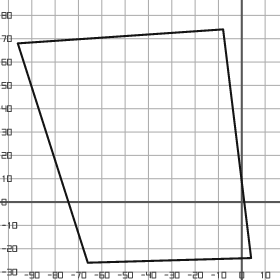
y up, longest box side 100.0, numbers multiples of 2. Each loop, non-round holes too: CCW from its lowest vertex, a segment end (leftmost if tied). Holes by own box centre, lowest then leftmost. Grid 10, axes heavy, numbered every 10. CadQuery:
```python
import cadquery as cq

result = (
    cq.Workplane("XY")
    .moveTo(-66.0, -26.0)
    .lineTo(4.0, -24.0)
    .lineTo(-8.0, 74.0)
    .lineTo(-96.0, 68.0)
    .close()
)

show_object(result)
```